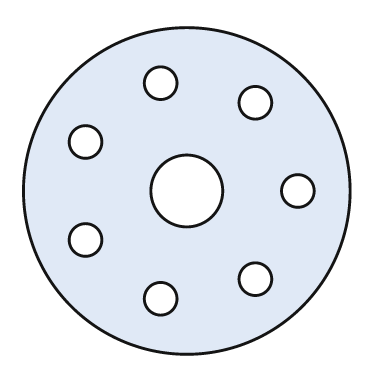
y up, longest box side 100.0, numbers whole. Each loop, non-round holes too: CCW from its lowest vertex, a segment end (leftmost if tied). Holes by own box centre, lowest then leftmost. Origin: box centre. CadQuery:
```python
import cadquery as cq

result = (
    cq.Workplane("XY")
    .moveTo(0.0, 0.0)
    .circle(50.0)
    .moveTo(-8.0, -33.0)
    .circle(5.0)
    .moveTo(21.0, -27.0)
    .circle(5.0)
    .moveTo(-31.0, -15.0)
    .circle(5.0)
    .moveTo(0.0, 0.0)
    .circle(11.0)
    .moveTo(34.0, 0.0)
    .circle(5.0)
    .moveTo(-31.0, 15.0)
    .circle(5.0)
    .moveTo(21.0, 27.0)
    .circle(5.0)
    .moveTo(-8.0, 33.0)
    .circle(5.0)
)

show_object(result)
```